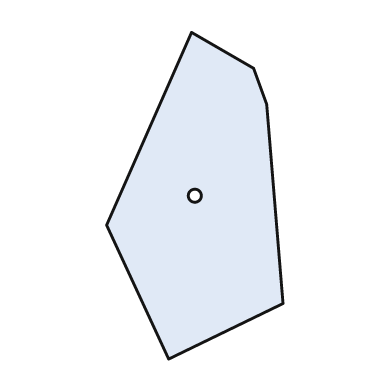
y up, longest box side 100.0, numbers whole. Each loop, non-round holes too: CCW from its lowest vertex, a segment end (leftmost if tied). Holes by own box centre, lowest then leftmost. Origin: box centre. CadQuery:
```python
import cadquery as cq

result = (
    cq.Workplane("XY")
    .moveTo(-8.0, -50.0)
    .lineTo(27.0, -33.0)
    .lineTo(22.0, 28.0)
    .lineTo(18.0, 39.0)
    .lineTo(-1.0, 50.0)
    .lineTo(-27.0, -9.0)
    .close()
    .moveTo(0.0, 0.0)
    .circle(2.0)
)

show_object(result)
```